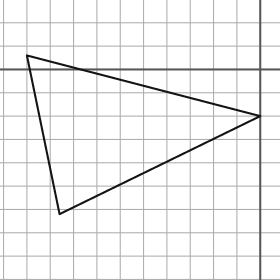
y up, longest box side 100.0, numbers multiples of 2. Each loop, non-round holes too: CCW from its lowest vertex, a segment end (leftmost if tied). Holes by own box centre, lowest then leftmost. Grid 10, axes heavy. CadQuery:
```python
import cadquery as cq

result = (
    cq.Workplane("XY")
    .moveTo(-86.0, -62.0)
    .lineTo(0.0, -20.0)
    .lineTo(-100.0, 6.0)
    .close()
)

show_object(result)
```